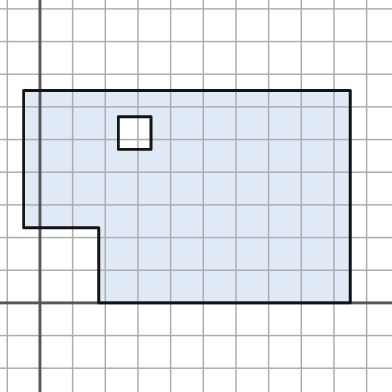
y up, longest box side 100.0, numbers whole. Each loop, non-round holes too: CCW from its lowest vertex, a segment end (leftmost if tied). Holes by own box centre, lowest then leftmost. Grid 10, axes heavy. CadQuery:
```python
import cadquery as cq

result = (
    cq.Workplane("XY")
    .moveTo(18.0, 0.0)
    .lineTo(95.0, 0.0)
    .lineTo(95.0, 65.0)
    .lineTo(-5.0, 65.0)
    .lineTo(-5.0, 23.0)
    .lineTo(18.0, 23.0)
    .close()
    .moveTo(24.0, 47.0)
    .lineTo(34.0, 47.0)
    .lineTo(34.0, 57.0)
    .lineTo(24.0, 57.0)
    .close()
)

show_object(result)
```